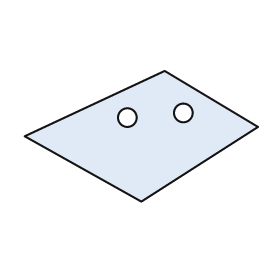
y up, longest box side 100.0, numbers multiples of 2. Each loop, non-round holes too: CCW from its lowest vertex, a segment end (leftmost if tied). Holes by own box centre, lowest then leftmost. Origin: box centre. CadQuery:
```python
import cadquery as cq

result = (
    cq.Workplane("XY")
    .moveTo(0.0, -28.0)
    .lineTo(50.0, 4.0)
    .lineTo(10.0, 28.0)
    .lineTo(-50.0, 0.0)
    .close()
    .moveTo(-6.0, 8.0)
    .circle(4.0)
    .moveTo(18.0, 10.0)
    .circle(4.0)
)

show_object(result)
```